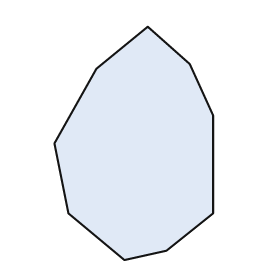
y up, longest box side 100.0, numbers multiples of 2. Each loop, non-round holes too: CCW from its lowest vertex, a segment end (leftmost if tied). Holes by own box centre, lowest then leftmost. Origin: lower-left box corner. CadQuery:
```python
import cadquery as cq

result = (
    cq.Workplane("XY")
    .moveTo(30.0, 0.0)
    .lineTo(48.0, 4.0)
    .lineTo(68.0, 20.0)
    .lineTo(68.0, 62.0)
    .lineTo(58.0, 84.0)
    .lineTo(40.0, 100.0)
    .lineTo(18.0, 82.0)
    .lineTo(0.0, 50.0)
    .lineTo(6.0, 20.0)
    .close()
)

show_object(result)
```